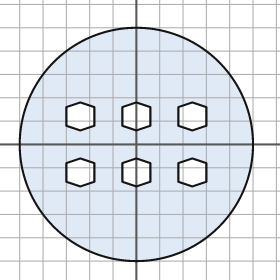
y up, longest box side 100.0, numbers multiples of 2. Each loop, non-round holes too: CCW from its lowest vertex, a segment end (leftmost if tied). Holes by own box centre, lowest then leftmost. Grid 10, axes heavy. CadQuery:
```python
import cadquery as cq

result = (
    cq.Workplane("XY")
    .moveTo(0.0, 0.0)
    .circle(50.0)
    .moveTo(-24.0, -18.0)
    .lineTo(-18.0, -16.0)
    .lineTo(-18.0, -8.0)
    .lineTo(-24.0, -6.0)
    .lineTo(-30.0, -8.0)
    .lineTo(-30.0, -16.0)
    .close()
    .moveTo(0.0, -18.0)
    .lineTo(6.0, -16.0)
    .lineTo(6.0, -8.0)
    .lineTo(0.0, -6.0)
    .lineTo(-6.0, -8.0)
    .lineTo(-6.0, -16.0)
    .close()
    .moveTo(24.0, -18.0)
    .lineTo(30.0, -16.0)
    .lineTo(30.0, -8.0)
    .lineTo(24.0, -6.0)
    .lineTo(18.0, -8.0)
    .lineTo(18.0, -16.0)
    .close()
    .moveTo(-24.0, 6.0)
    .lineTo(-18.0, 8.0)
    .lineTo(-18.0, 16.0)
    .lineTo(-24.0, 18.0)
    .lineTo(-30.0, 16.0)
    .lineTo(-30.0, 8.0)
    .close()
    .moveTo(0.0, 6.0)
    .lineTo(6.0, 8.0)
    .lineTo(6.0, 16.0)
    .lineTo(0.0, 18.0)
    .lineTo(-6.0, 16.0)
    .lineTo(-6.0, 8.0)
    .close()
    .moveTo(24.0, 6.0)
    .lineTo(30.0, 8.0)
    .lineTo(30.0, 16.0)
    .lineTo(24.0, 18.0)
    .lineTo(18.0, 16.0)
    .lineTo(18.0, 8.0)
    .close()
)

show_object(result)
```